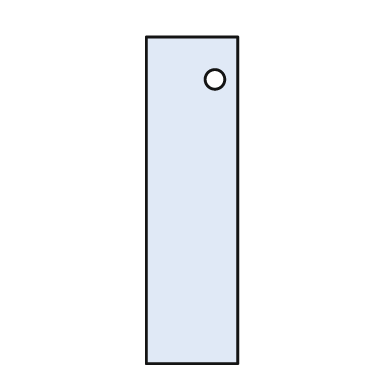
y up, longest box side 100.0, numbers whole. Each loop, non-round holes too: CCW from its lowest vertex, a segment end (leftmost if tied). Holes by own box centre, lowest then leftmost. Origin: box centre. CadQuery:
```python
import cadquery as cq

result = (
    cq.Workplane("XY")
    .moveTo(-14.0, -50.0)
    .lineTo(14.0, -50.0)
    .lineTo(14.0, 50.0)
    .lineTo(-14.0, 50.0)
    .close()
    .moveTo(7.0, 37.0)
    .circle(3.0)
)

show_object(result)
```